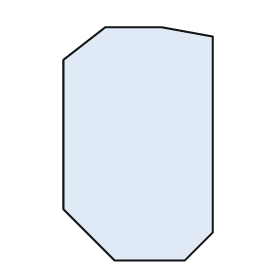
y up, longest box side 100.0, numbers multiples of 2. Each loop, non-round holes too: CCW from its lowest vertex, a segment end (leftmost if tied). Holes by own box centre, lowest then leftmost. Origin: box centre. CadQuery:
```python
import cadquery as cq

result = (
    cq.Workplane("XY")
    .moveTo(-10.0, -50.0)
    .lineTo(20.0, -50.0)
    .lineTo(32.0, -38.0)
    .lineTo(32.0, 46.0)
    .lineTo(10.0, 50.0)
    .lineTo(-14.0, 50.0)
    .lineTo(-32.0, 36.0)
    .lineTo(-32.0, -28.0)
    .close()
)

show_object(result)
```